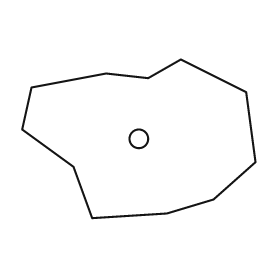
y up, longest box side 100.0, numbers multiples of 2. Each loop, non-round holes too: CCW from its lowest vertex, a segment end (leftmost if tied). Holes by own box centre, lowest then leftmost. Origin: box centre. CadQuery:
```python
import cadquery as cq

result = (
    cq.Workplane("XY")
    .moveTo(-20.0, -34.0)
    .lineTo(12.0, -32.0)
    .lineTo(32.0, -26.0)
    .lineTo(50.0, -10.0)
    .lineTo(46.0, 20.0)
    .lineTo(18.0, 34.0)
    .lineTo(4.0, 26.0)
    .lineTo(-14.0, 28.0)
    .lineTo(-46.0, 22.0)
    .lineTo(-50.0, 4.0)
    .lineTo(-28.0, -12.0)
    .close()
    .moveTo(0.0, 0.0)
    .circle(4.0)
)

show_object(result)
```